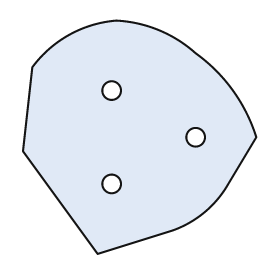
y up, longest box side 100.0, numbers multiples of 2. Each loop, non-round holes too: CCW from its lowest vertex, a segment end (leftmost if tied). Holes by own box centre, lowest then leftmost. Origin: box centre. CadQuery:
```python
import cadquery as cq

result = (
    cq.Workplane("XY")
    .moveTo(-18.0, -50.0)
    .lineTo(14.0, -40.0)
    .threePointArc((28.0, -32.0), (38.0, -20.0))
    .lineTo(50.0, 0.0)
    .threePointArc((40.0, 20.0), (24.0, 36.0))
    .threePointArc((8.0, 46.0), (-10.0, 50.0))
    .threePointArc((-30.0, 44.0), (-46.0, 30.0))
    .lineTo(-50.0, -6.0)
    .close()
    .moveTo(-12.0, -20.0)
    .circle(4.0)
    .moveTo(24.0, 0.0)
    .circle(4.0)
    .moveTo(-12.0, 20.0)
    .circle(4.0)
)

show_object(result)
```